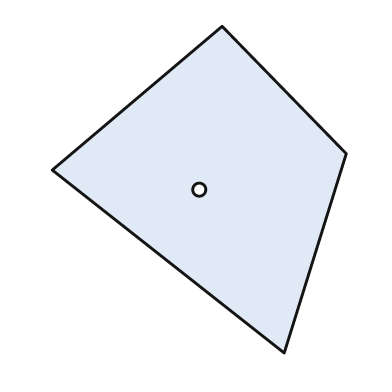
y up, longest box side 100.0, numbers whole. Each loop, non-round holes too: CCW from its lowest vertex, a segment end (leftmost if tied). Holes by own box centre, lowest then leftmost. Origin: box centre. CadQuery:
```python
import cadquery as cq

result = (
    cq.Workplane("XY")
    .moveTo(26.0, -50.0)
    .lineTo(45.0, 11.0)
    .lineTo(7.0, 50.0)
    .lineTo(-45.0, 6.0)
    .close()
    .moveTo(0.0, 0.0)
    .circle(2.0)
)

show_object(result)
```